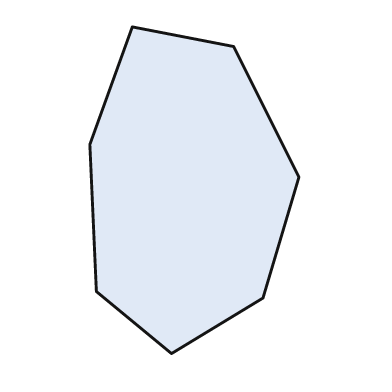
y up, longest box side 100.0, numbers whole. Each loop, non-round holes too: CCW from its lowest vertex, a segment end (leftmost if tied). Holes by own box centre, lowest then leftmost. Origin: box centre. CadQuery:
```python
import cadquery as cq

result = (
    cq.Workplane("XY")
    .moveTo(-7.0, -50.0)
    .lineTo(21.0, -33.0)
    .lineTo(32.0, 4.0)
    .lineTo(12.0, 44.0)
    .lineTo(-19.0, 50.0)
    .lineTo(-32.0, 14.0)
    .lineTo(-30.0, -31.0)
    .close()
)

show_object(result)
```